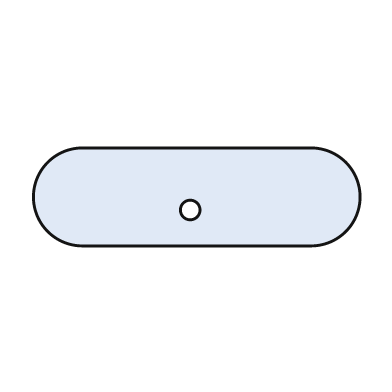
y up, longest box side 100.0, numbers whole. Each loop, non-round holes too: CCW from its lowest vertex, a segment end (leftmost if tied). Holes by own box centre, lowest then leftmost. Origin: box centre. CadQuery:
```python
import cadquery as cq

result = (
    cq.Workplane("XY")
    .moveTo(-35.0, -15.0)
    .lineTo(35.0, -15.0)
    .threePointArc((50.0, 0.0), (35.0, 15.0))
    .lineTo(-35.0, 15.0)
    .threePointArc((-50.0, 0.0), (-35.0, -15.0))
    .close()
    .moveTo(-2.0, -4.0)
    .circle(3.0)
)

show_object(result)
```